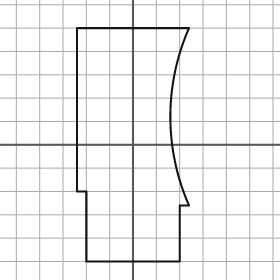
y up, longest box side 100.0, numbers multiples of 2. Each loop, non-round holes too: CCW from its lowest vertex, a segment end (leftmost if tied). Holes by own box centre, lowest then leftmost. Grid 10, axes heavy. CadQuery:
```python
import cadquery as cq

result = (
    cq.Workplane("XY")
    .moveTo(-20.0, -50.0)
    .lineTo(20.0, -50.0)
    .lineTo(20.0, -26.0)
    .lineTo(24.0, -26.0)
    .threePointArc((16.0, 12.0), (24.0, 50.0))
    .lineTo(-24.0, 50.0)
    .lineTo(-24.0, -20.0)
    .lineTo(-20.0, -20.0)
    .close()
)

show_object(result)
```